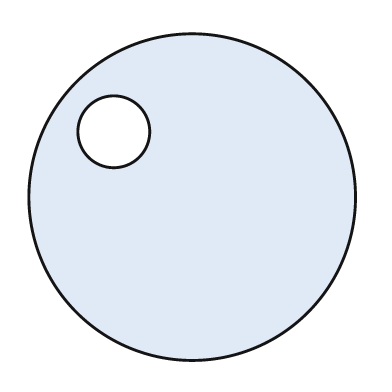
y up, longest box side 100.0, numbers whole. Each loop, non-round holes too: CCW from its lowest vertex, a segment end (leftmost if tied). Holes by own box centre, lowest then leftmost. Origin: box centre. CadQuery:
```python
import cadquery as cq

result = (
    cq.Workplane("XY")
    .moveTo(0.0, 0.0)
    .circle(50.0)
    .moveTo(-24.0, 20.0)
    .circle(11.0)
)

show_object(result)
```